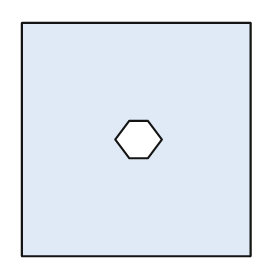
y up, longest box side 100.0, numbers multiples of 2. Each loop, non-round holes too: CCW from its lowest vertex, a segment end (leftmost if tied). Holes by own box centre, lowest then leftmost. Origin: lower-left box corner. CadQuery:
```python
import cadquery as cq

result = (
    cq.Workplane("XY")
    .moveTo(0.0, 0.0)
    .lineTo(98.0, 0.0)
    .lineTo(98.0, 100.0)
    .lineTo(0.0, 100.0)
    .close()
    .moveTo(46.0, 42.0)
    .lineTo(54.0, 42.0)
    .lineTo(60.0, 50.0)
    .lineTo(54.0, 58.0)
    .lineTo(46.0, 58.0)
    .lineTo(40.0, 50.0)
    .close()
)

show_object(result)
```